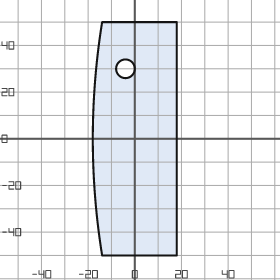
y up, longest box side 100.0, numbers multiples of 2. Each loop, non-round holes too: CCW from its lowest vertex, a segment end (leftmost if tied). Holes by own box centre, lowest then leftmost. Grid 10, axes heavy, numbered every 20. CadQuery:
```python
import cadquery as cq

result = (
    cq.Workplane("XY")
    .moveTo(-14.0, -50.0)
    .lineTo(18.0, -50.0)
    .lineTo(18.0, 50.0)
    .lineTo(-14.0, 50.0)
    .threePointArc((-18.0, 0.0), (-14.0, -50.0))
    .close()
    .moveTo(-4.0, 30.0)
    .circle(4.0)
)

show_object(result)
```